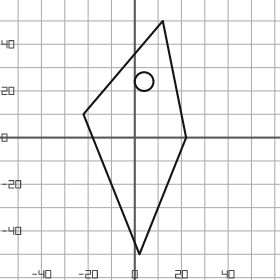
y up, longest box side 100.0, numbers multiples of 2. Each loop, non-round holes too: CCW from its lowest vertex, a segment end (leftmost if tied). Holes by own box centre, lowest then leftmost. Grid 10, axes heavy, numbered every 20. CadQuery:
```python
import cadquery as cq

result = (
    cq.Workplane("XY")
    .moveTo(2.0, -50.0)
    .lineTo(22.0, 0.0)
    .lineTo(12.0, 50.0)
    .lineTo(-22.0, 10.0)
    .close()
    .moveTo(4.0, 24.0)
    .circle(4.0)
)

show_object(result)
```